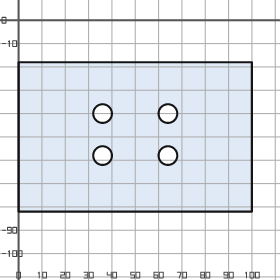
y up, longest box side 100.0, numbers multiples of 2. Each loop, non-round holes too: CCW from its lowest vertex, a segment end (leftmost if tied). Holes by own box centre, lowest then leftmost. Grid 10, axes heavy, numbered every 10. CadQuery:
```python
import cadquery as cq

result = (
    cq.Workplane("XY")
    .moveTo(0.0, -82.0)
    .lineTo(100.0, -82.0)
    .lineTo(100.0, -18.0)
    .lineTo(0.0, -18.0)
    .close()
    .moveTo(36.0, -58.0)
    .circle(4.0)
    .moveTo(64.0, -58.0)
    .circle(4.0)
    .moveTo(36.0, -40.0)
    .circle(4.0)
    .moveTo(64.0, -40.0)
    .circle(4.0)
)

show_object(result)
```